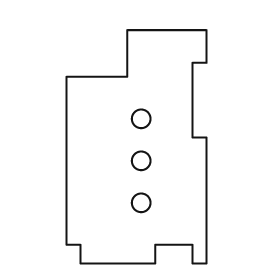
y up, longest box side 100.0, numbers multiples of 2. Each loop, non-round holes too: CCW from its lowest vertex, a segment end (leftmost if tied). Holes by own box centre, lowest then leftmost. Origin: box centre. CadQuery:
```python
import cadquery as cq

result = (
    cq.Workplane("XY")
    .moveTo(-24.0, -50.0)
    .lineTo(8.0, -50.0)
    .lineTo(8.0, -42.0)
    .lineTo(24.0, -42.0)
    .lineTo(24.0, -50.0)
    .lineTo(30.0, -50.0)
    .lineTo(30.0, 4.0)
    .lineTo(24.0, 4.0)
    .lineTo(24.0, 36.0)
    .lineTo(30.0, 36.0)
    .lineTo(30.0, 50.0)
    .lineTo(-4.0, 50.0)
    .lineTo(-4.0, 30.0)
    .lineTo(-30.0, 30.0)
    .lineTo(-30.0, -42.0)
    .lineTo(-24.0, -42.0)
    .close()
    .moveTo(2.0, -24.0)
    .circle(4.0)
    .moveTo(2.0, -6.0)
    .circle(4.0)
    .moveTo(2.0, 12.0)
    .circle(4.0)
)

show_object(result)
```